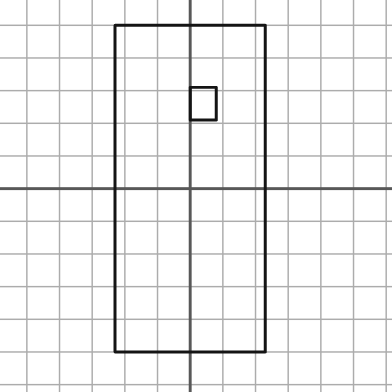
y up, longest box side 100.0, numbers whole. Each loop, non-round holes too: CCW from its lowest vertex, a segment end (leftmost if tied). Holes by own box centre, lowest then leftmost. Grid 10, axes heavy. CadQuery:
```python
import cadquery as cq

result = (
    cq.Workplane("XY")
    .moveTo(-23.0, -50.0)
    .lineTo(23.0, -50.0)
    .lineTo(23.0, 50.0)
    .lineTo(-23.0, 50.0)
    .close()
    .moveTo(0.0, 21.0)
    .lineTo(8.0, 21.0)
    .lineTo(8.0, 31.0)
    .lineTo(0.0, 31.0)
    .close()
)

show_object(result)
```